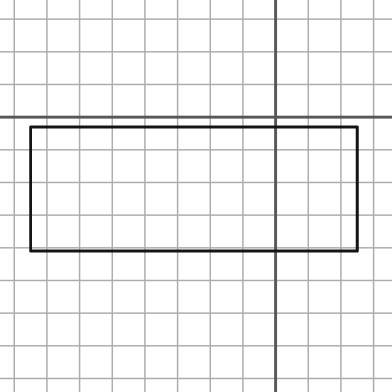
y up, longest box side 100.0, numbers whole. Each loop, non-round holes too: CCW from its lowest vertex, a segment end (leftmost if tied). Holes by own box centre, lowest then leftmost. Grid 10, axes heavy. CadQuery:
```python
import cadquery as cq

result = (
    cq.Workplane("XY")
    .moveTo(-75.0, -41.0)
    .lineTo(25.0, -41.0)
    .lineTo(25.0, -3.0)
    .lineTo(-75.0, -3.0)
    .close()
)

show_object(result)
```